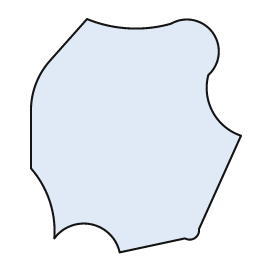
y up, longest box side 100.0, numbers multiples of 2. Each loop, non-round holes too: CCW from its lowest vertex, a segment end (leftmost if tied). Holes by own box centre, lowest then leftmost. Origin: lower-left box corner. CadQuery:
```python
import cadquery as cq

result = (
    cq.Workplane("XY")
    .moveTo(38.0, 0.0)
    .lineTo(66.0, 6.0)
    .threePointArc((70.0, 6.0), (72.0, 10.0))
    .lineTo(90.0, 50.0)
    .threePointArc((78.0, 60.0), (76.0, 76.0))
    .threePointArc((78.0, 94.0), (60.0, 98.0))
    .threePointArc((42.0, 96.0), (24.0, 100.0))
    .lineTo(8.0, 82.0)
    .threePointArc((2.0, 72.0), (0.0, 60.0))
    .lineTo(0.0, 36.0)
    .threePointArc((8.0, 22.0), (10.0, 6.0))
    .threePointArc((26.0, 12.0), (38.0, 0.0))
    .close()
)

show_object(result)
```